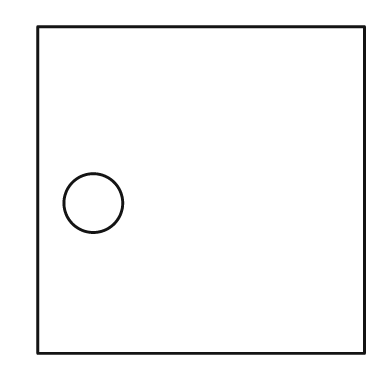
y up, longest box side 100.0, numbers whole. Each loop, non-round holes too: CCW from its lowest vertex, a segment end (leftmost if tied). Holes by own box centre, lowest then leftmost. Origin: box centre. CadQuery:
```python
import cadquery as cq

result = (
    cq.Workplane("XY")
    .moveTo(-50.0, -50.0)
    .lineTo(50.0, -50.0)
    .lineTo(50.0, 50.0)
    .lineTo(-50.0, 50.0)
    .close()
    .moveTo(-33.0, -4.0)
    .circle(9.0)
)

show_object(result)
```